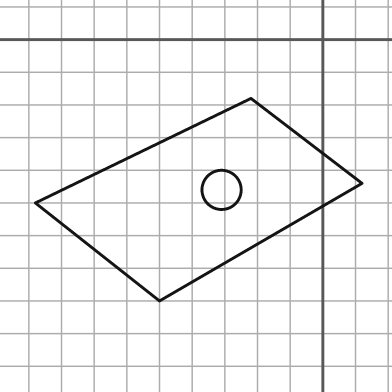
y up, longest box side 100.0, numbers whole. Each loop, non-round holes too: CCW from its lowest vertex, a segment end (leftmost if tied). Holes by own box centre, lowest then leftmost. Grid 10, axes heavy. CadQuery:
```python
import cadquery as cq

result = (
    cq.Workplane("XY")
    .moveTo(-50.0, -80.0)
    .lineTo(12.0, -44.0)
    .lineTo(-22.0, -18.0)
    .lineTo(-88.0, -50.0)
    .close()
    .moveTo(-31.0, -46.0)
    .circle(6.0)
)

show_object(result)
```